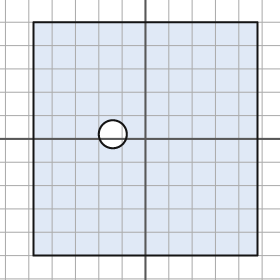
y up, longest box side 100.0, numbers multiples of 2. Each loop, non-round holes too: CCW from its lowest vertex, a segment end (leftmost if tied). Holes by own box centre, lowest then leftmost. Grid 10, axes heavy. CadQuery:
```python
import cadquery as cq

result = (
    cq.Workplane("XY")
    .moveTo(-48.0, -50.0)
    .lineTo(48.0, -50.0)
    .lineTo(48.0, 50.0)
    .lineTo(-48.0, 50.0)
    .close()
    .moveTo(-14.0, 2.0)
    .circle(6.0)
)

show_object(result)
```